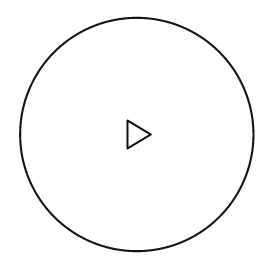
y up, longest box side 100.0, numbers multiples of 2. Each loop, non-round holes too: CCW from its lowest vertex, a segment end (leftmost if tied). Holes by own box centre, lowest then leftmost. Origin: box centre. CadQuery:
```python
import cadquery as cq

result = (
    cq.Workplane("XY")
    .moveTo(0.0, 0.0)
    .circle(50.0)
    .moveTo(-4.0, -6.0)
    .lineTo(6.0, 0.0)
    .lineTo(-4.0, 6.0)
    .close()
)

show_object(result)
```